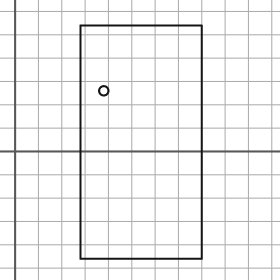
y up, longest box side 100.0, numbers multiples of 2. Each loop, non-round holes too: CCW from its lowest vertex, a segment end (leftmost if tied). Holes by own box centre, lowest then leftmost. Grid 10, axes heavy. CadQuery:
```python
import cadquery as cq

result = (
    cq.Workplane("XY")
    .moveTo(28.0, -46.0)
    .lineTo(80.0, -46.0)
    .lineTo(80.0, 54.0)
    .lineTo(28.0, 54.0)
    .close()
    .moveTo(38.0, 26.0)
    .circle(2.0)
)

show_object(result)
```